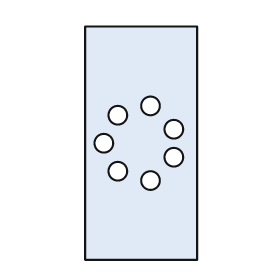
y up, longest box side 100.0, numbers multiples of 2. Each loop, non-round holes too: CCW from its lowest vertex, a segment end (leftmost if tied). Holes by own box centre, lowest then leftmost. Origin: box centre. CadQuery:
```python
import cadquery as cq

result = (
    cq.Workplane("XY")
    .moveTo(-24.0, -50.0)
    .lineTo(24.0, -50.0)
    .lineTo(24.0, 50.0)
    .lineTo(-24.0, 50.0)
    .close()
    .moveTo(4.0, -16.0)
    .circle(4.0)
    .moveTo(-10.0, -12.0)
    .circle(4.0)
    .moveTo(14.0, -6.0)
    .circle(4.0)
    .moveTo(-16.0, 0.0)
    .circle(4.0)
    .moveTo(14.0, 6.0)
    .circle(4.0)
    .moveTo(-10.0, 12.0)
    .circle(4.0)
    .moveTo(4.0, 16.0)
    .circle(4.0)
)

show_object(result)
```